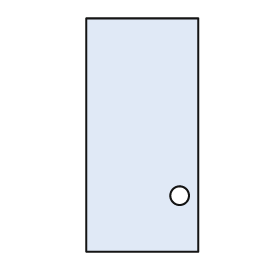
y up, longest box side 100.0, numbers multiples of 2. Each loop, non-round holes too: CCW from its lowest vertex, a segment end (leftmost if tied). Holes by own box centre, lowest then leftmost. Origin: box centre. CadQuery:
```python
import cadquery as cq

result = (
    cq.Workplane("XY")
    .moveTo(-24.0, -50.0)
    .lineTo(24.0, -50.0)
    .lineTo(24.0, 50.0)
    .lineTo(-24.0, 50.0)
    .close()
    .moveTo(16.0, -26.0)
    .circle(4.0)
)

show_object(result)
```